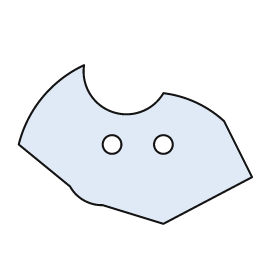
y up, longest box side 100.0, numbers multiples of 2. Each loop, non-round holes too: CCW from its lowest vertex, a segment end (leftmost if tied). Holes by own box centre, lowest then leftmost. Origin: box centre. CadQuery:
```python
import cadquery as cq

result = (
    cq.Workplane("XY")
    .moveTo(12.0, -34.0)
    .lineTo(50.0, -14.0)
    .lineTo(38.0, 10.0)
    .threePointArc((26.0, 18.0), (12.0, 22.0))
    .threePointArc((-10.0, 14.0), (-22.0, 34.0))
    .threePointArc((-40.0, 20.0), (-50.0, 0.0))
    .lineTo(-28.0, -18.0)
    .threePointArc((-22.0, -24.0), (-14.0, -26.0))
    .close()
    .moveTo(-10.0, 0.0)
    .circle(4.0)
    .moveTo(12.0, 0.0)
    .circle(4.0)
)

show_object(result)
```